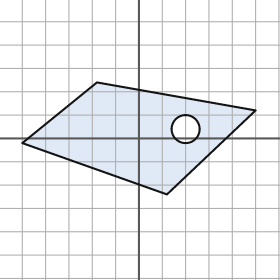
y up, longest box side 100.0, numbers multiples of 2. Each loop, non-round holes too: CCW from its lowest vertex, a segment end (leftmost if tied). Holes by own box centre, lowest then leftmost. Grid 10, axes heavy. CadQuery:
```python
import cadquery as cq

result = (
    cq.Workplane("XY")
    .moveTo(12.0, -24.0)
    .lineTo(50.0, 12.0)
    .lineTo(-18.0, 24.0)
    .lineTo(-50.0, -2.0)
    .close()
    .moveTo(20.0, 4.0)
    .circle(6.0)
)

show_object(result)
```